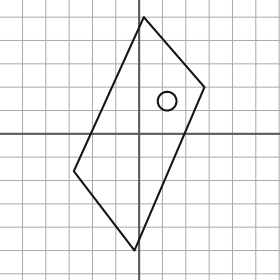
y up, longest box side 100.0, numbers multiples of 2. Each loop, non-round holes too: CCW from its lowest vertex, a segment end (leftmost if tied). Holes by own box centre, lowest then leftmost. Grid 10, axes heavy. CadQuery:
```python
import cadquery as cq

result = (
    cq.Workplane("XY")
    .moveTo(-2.0, -50.0)
    .lineTo(28.0, 20.0)
    .lineTo(2.0, 50.0)
    .lineTo(-28.0, -16.0)
    .close()
    .moveTo(12.0, 14.0)
    .circle(4.0)
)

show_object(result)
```